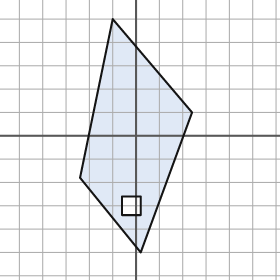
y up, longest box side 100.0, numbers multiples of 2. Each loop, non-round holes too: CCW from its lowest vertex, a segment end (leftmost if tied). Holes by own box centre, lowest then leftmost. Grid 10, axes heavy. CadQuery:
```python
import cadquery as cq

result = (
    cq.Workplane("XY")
    .moveTo(2.0, -50.0)
    .lineTo(24.0, 10.0)
    .lineTo(-10.0, 50.0)
    .lineTo(-24.0, -18.0)
    .close()
    .moveTo(-6.0, -34.0)
    .lineTo(2.0, -34.0)
    .lineTo(2.0, -26.0)
    .lineTo(-6.0, -26.0)
    .close()
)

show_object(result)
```